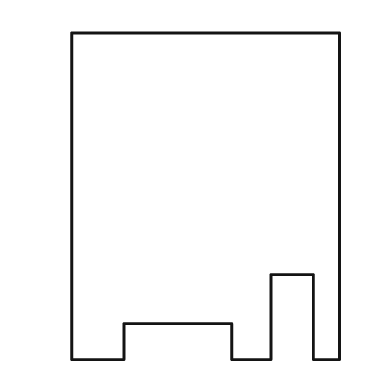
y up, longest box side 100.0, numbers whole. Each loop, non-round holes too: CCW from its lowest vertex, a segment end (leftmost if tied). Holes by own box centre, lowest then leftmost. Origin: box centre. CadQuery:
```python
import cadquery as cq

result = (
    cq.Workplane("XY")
    .moveTo(-41.0, -50.0)
    .lineTo(-25.0, -50.0)
    .lineTo(-25.0, -39.0)
    .lineTo(8.0, -39.0)
    .lineTo(8.0, -50.0)
    .lineTo(20.0, -50.0)
    .lineTo(20.0, -24.0)
    .lineTo(33.0, -24.0)
    .lineTo(33.0, -50.0)
    .lineTo(41.0, -50.0)
    .lineTo(41.0, 50.0)
    .lineTo(-41.0, 50.0)
    .close()
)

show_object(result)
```